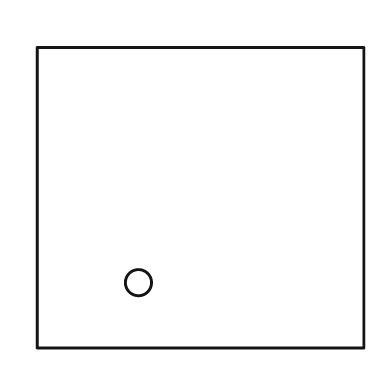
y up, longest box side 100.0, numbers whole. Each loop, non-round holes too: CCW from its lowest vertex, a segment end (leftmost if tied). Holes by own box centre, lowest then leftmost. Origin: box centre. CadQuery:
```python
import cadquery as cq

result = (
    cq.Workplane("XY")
    .moveTo(-50.0, -46.0)
    .lineTo(50.0, -46.0)
    .lineTo(50.0, 46.0)
    .lineTo(-50.0, 46.0)
    .close()
    .moveTo(-19.0, -26.0)
    .circle(4.0)
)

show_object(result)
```